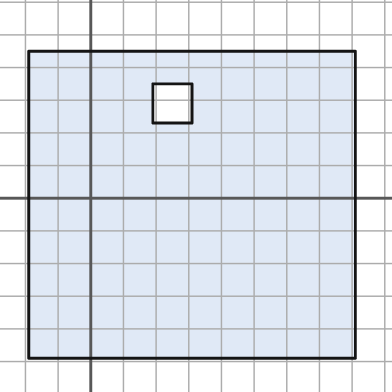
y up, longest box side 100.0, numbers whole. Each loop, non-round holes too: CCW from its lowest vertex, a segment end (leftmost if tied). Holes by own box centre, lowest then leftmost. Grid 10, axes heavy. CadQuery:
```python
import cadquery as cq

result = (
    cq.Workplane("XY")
    .moveTo(-19.0, -49.0)
    .lineTo(81.0, -49.0)
    .lineTo(81.0, 45.0)
    .lineTo(-19.0, 45.0)
    .close()
    .moveTo(19.0, 23.0)
    .lineTo(31.0, 23.0)
    .lineTo(31.0, 35.0)
    .lineTo(19.0, 35.0)
    .close()
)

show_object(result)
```